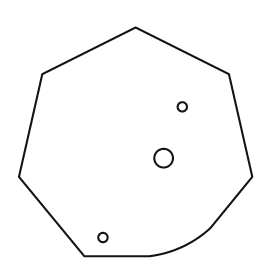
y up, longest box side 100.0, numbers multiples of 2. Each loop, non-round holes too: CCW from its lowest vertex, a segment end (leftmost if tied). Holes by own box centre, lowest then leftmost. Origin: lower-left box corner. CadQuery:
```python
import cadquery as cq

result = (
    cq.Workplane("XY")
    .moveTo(28.0, 0.0)
    .lineTo(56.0, 0.0)
    .threePointArc((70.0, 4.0), (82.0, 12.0))
    .lineTo(100.0, 34.0)
    .lineTo(90.0, 78.0)
    .lineTo(50.0, 98.0)
    .lineTo(10.0, 78.0)
    .lineTo(0.0, 34.0)
    .close()
    .moveTo(36.0, 8.0)
    .circle(2.0)
    .moveTo(62.0, 42.0)
    .circle(4.0)
    .moveTo(70.0, 64.0)
    .circle(2.0)
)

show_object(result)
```